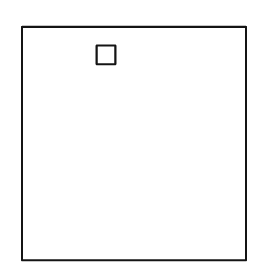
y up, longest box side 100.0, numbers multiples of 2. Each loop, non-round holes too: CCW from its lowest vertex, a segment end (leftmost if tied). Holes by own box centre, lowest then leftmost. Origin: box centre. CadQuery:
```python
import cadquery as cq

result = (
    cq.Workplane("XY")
    .moveTo(-48.0, -50.0)
    .lineTo(48.0, -50.0)
    .lineTo(48.0, 50.0)
    .lineTo(-48.0, 50.0)
    .close()
    .moveTo(-16.0, 34.0)
    .lineTo(-8.0, 34.0)
    .lineTo(-8.0, 42.0)
    .lineTo(-16.0, 42.0)
    .close()
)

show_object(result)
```